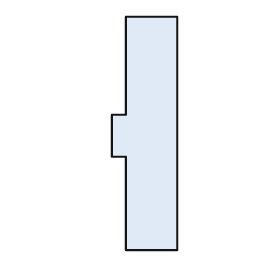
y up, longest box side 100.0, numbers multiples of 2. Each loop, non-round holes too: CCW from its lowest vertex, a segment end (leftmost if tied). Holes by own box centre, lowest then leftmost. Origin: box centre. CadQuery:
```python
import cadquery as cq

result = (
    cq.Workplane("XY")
    .moveTo(-8.0, -50.0)
    .lineTo(14.0, -50.0)
    .lineTo(14.0, 50.0)
    .lineTo(-8.0, 50.0)
    .lineTo(-8.0, 8.0)
    .lineTo(-14.0, 8.0)
    .lineTo(-14.0, -10.0)
    .lineTo(-8.0, -10.0)
    .close()
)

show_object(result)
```